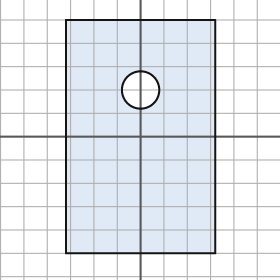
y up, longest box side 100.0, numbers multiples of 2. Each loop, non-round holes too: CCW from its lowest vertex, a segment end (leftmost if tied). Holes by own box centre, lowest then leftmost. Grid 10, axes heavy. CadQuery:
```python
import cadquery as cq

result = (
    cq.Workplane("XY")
    .moveTo(-32.0, -50.0)
    .lineTo(32.0, -50.0)
    .lineTo(32.0, 50.0)
    .lineTo(-32.0, 50.0)
    .close()
    .moveTo(0.0, 20.0)
    .circle(8.0)
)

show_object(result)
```